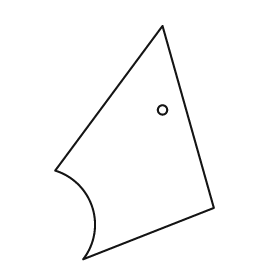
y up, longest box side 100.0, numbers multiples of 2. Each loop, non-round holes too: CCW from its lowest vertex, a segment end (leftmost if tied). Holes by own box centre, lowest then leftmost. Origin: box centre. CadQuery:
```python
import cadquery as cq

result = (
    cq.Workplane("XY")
    .moveTo(-22.0, -50.0)
    .lineTo(34.0, -28.0)
    .lineTo(12.0, 50.0)
    .lineTo(-34.0, -12.0)
    .threePointArc((-18.0, -28.0), (-22.0, -50.0))
    .close()
    .moveTo(12.0, 14.0)
    .circle(2.0)
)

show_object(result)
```